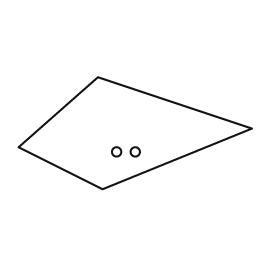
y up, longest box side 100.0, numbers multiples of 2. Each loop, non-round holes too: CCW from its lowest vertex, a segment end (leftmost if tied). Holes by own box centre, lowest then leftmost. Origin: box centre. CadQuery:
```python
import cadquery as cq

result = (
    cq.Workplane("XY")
    .moveTo(-14.0, -24.0)
    .lineTo(50.0, 2.0)
    .lineTo(-16.0, 24.0)
    .lineTo(-50.0, -6.0)
    .close()
    .moveTo(-8.0, -8.0)
    .circle(2.0)
    .moveTo(0.0, -8.0)
    .circle(2.0)
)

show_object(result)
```